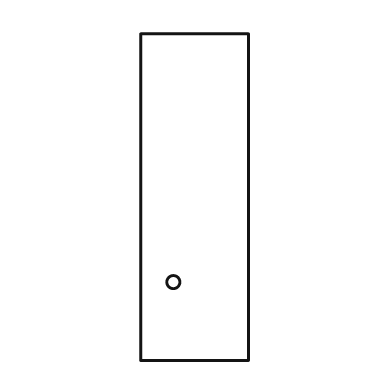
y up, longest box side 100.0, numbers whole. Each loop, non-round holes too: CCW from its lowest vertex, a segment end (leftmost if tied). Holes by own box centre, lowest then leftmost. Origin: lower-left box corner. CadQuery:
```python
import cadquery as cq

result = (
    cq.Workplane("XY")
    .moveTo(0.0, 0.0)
    .lineTo(33.0, 0.0)
    .lineTo(33.0, 100.0)
    .lineTo(0.0, 100.0)
    .close()
    .moveTo(10.0, 24.0)
    .circle(2.0)
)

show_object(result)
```